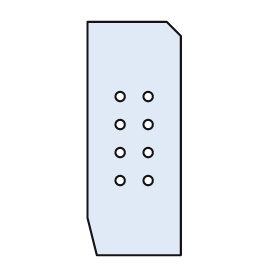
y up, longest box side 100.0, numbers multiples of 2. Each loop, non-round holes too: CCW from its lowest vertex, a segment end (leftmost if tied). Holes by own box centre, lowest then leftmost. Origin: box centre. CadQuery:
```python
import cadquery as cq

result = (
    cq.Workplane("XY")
    .moveTo(-16.0, -50.0)
    .lineTo(20.0, -50.0)
    .lineTo(20.0, 44.0)
    .lineTo(14.0, 50.0)
    .lineTo(-20.0, 50.0)
    .lineTo(-20.0, -34.0)
    .close()
    .moveTo(-6.0, -18.0)
    .circle(2.0)
    .moveTo(6.0, -18.0)
    .circle(2.0)
    .moveTo(-6.0, -6.0)
    .circle(2.0)
    .moveTo(6.0, -6.0)
    .circle(2.0)
    .moveTo(-6.0, 6.0)
    .circle(2.0)
    .moveTo(6.0, 6.0)
    .circle(2.0)
    .moveTo(-6.0, 18.0)
    .circle(2.0)
    .moveTo(6.0, 18.0)
    .circle(2.0)
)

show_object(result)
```